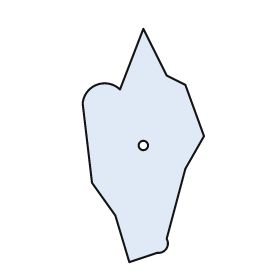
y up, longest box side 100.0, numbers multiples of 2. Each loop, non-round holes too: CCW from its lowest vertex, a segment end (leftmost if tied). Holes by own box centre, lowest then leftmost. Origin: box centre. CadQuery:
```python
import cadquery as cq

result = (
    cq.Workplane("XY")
    .moveTo(-6.0, -50.0)
    .lineTo(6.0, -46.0)
    .threePointArc((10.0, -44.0), (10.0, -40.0))
    .lineTo(18.0, -10.0)
    .lineTo(26.0, 4.0)
    .lineTo(18.0, 26.0)
    .lineTo(10.0, 30.0)
    .lineTo(0.0, 50.0)
    .lineTo(-10.0, 24.0)
    .threePointArc((-20.0, 26.0), (-26.0, 18.0))
    .lineTo(-22.0, -16.0)
    .lineTo(-12.0, -30.0)
    .close()
    .moveTo(0.0, 0.0)
    .circle(2.0)
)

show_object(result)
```